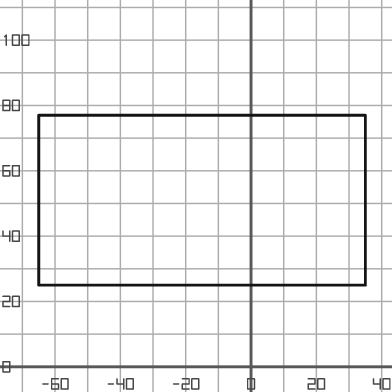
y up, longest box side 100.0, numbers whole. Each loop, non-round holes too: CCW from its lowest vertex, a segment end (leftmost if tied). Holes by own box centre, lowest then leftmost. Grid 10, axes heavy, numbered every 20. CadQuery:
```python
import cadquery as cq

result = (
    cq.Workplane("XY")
    .moveTo(-65.0, 25.0)
    .lineTo(35.0, 25.0)
    .lineTo(35.0, 77.0)
    .lineTo(-65.0, 77.0)
    .close()
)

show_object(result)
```